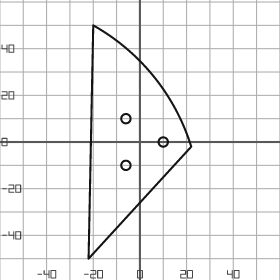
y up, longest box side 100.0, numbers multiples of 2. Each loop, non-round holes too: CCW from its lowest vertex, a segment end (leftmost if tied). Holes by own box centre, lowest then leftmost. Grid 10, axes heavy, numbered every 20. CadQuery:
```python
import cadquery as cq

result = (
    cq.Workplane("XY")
    .moveTo(-22.0, -50.0)
    .lineTo(22.0, -2.0)
    .threePointArc((6.0, 28.0), (-20.0, 50.0))
    .close()
    .moveTo(-6.0, -10.0)
    .circle(2.0)
    .moveTo(10.0, 0.0)
    .circle(2.0)
    .moveTo(-6.0, 10.0)
    .circle(2.0)
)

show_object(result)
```